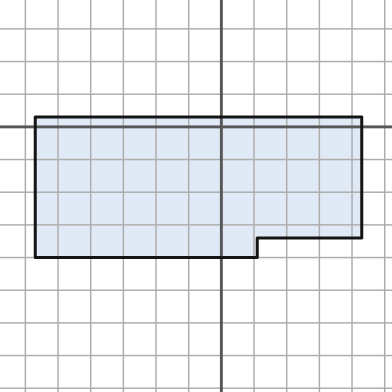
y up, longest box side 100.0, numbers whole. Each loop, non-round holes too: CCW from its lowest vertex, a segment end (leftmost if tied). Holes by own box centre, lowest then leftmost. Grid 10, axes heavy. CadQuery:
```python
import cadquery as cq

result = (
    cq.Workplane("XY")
    .moveTo(-57.0, -40.0)
    .lineTo(11.0, -40.0)
    .lineTo(11.0, -34.0)
    .lineTo(43.0, -34.0)
    .lineTo(43.0, 3.0)
    .lineTo(-57.0, 3.0)
    .close()
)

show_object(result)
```